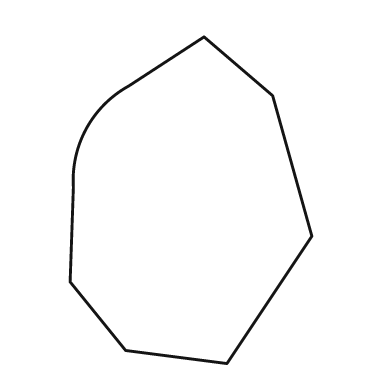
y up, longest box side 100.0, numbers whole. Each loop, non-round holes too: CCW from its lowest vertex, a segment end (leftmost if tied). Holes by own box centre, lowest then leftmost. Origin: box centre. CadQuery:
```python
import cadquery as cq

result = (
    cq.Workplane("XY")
    .moveTo(11.0, -50.0)
    .lineTo(37.0, -11.0)
    .lineTo(25.0, 32.0)
    .lineTo(4.0, 50.0)
    .lineTo(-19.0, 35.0)
    .threePointArc((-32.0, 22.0), (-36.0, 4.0))
    .lineTo(-37.0, -25.0)
    .lineTo(-20.0, -46.0)
    .close()
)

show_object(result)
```